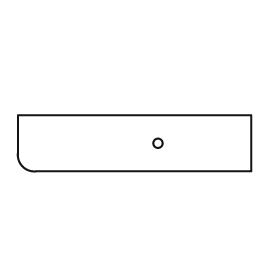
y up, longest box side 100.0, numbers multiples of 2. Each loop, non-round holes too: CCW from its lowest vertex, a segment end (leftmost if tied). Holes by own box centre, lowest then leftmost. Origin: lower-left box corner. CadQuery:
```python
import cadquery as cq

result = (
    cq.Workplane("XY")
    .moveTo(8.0, 0.0)
    .lineTo(100.0, 0.0)
    .lineTo(100.0, 24.0)
    .lineTo(0.0, 24.0)
    .lineTo(0.0, 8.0)
    .threePointArc((2.0, 2.0), (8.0, 0.0))
    .close()
    .moveTo(60.0, 12.0)
    .circle(2.0)
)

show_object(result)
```